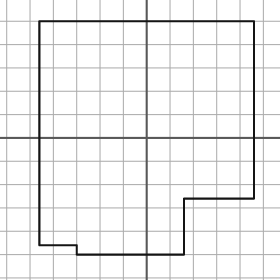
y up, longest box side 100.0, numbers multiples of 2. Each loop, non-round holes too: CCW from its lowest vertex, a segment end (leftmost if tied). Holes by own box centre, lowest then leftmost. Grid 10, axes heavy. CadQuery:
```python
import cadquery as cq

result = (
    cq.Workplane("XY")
    .moveTo(-30.0, -50.0)
    .lineTo(16.0, -50.0)
    .lineTo(16.0, -26.0)
    .lineTo(46.0, -26.0)
    .lineTo(46.0, 50.0)
    .lineTo(-46.0, 50.0)
    .lineTo(-46.0, -46.0)
    .lineTo(-30.0, -46.0)
    .close()
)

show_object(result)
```